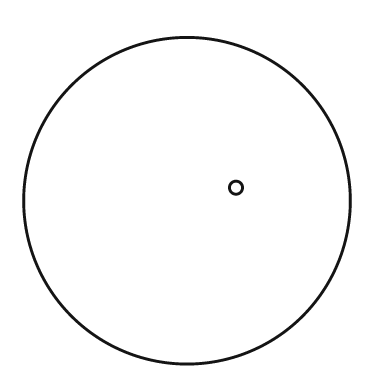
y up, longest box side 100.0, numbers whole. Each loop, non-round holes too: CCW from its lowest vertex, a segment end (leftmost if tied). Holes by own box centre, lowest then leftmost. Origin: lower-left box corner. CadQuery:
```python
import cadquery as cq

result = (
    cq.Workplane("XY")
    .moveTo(50.0, 50.0)
    .circle(50.0)
    .moveTo(65.0, 54.0)
    .circle(2.0)
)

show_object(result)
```